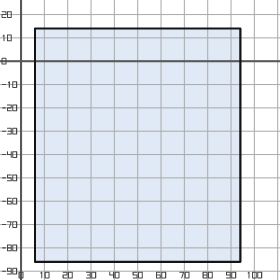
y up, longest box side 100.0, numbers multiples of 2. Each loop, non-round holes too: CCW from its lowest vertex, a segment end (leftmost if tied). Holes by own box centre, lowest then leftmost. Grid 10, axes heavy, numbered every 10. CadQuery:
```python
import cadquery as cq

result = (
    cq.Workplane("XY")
    .moveTo(6.0, -86.0)
    .lineTo(94.0, -86.0)
    .lineTo(94.0, 14.0)
    .lineTo(6.0, 14.0)
    .close()
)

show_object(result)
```